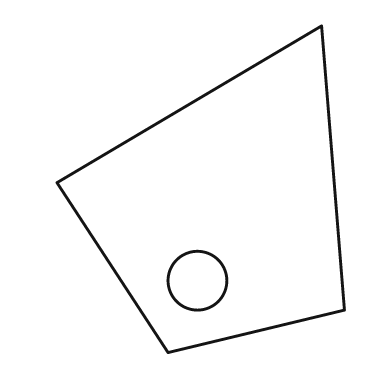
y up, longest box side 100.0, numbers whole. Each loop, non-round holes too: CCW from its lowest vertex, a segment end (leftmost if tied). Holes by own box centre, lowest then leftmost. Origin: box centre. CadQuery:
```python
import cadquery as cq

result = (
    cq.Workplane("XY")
    .moveTo(-10.0, -50.0)
    .lineTo(44.0, -37.0)
    .lineTo(37.0, 50.0)
    .lineTo(-44.0, 2.0)
    .close()
    .moveTo(-1.0, -28.0)
    .circle(9.0)
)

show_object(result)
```